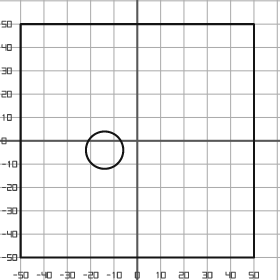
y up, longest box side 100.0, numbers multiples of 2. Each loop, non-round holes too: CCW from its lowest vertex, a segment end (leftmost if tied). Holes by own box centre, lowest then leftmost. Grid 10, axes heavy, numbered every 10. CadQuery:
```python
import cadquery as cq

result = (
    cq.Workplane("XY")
    .moveTo(-50.0, -50.0)
    .lineTo(50.0, -50.0)
    .lineTo(50.0, 50.0)
    .lineTo(-50.0, 50.0)
    .close()
    .moveTo(-14.0, -4.0)
    .circle(8.0)
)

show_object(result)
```